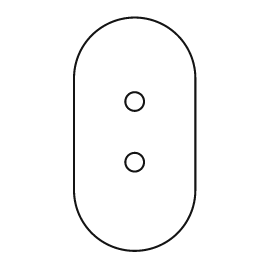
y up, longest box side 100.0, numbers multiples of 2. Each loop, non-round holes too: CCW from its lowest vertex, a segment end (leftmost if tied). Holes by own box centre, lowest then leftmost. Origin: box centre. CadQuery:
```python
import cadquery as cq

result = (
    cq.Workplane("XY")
    .moveTo(-26.0, -24.0)
    .threePointArc((0.0, -50.0), (26.0, -24.0))
    .lineTo(26.0, 24.0)
    .threePointArc((0.0, 50.0), (-26.0, 24.0))
    .close()
    .moveTo(0.0, -12.0)
    .circle(4.0)
    .moveTo(0.0, 14.0)
    .circle(4.0)
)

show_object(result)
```